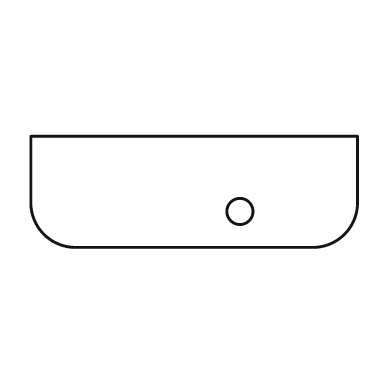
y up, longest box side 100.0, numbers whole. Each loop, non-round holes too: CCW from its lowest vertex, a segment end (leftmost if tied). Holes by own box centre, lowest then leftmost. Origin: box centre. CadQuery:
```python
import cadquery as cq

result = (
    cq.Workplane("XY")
    .moveTo(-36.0, -17.0)
    .lineTo(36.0, -17.0)
    .threePointArc((46.0, -13.0), (50.0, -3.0))
    .lineTo(50.0, 17.0)
    .lineTo(-50.0, 17.0)
    .lineTo(-50.0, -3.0)
    .threePointArc((-46.0, -13.0), (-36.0, -17.0))
    .close()
    .moveTo(14.0, -6.0)
    .circle(4.0)
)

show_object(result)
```